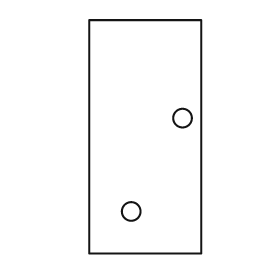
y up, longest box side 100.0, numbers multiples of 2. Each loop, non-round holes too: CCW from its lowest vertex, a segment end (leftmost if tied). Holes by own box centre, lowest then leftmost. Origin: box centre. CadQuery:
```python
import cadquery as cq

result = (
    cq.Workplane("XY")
    .moveTo(-24.0, -50.0)
    .lineTo(24.0, -50.0)
    .lineTo(24.0, 50.0)
    .lineTo(-24.0, 50.0)
    .close()
    .moveTo(-6.0, -32.0)
    .circle(4.0)
    .moveTo(16.0, 8.0)
    .circle(4.0)
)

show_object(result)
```